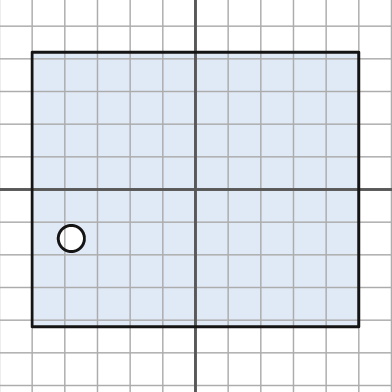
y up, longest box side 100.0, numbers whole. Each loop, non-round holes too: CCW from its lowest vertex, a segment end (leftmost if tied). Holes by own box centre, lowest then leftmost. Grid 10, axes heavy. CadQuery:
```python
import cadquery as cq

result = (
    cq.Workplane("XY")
    .moveTo(-50.0, -42.0)
    .lineTo(50.0, -42.0)
    .lineTo(50.0, 42.0)
    .lineTo(-50.0, 42.0)
    .close()
    .moveTo(-38.0, -15.0)
    .circle(4.0)
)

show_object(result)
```